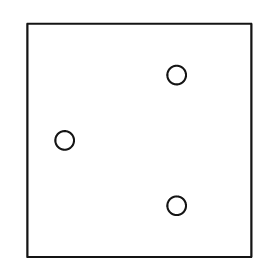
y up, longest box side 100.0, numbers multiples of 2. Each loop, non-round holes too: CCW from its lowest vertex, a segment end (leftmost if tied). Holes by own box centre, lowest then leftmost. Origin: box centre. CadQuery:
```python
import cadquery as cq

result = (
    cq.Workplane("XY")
    .moveTo(-48.0, -50.0)
    .lineTo(48.0, -50.0)
    .lineTo(48.0, 50.0)
    .lineTo(-48.0, 50.0)
    .close()
    .moveTo(16.0, -28.0)
    .circle(4.0)
    .moveTo(-32.0, 0.0)
    .circle(4.0)
    .moveTo(16.0, 28.0)
    .circle(4.0)
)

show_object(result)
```